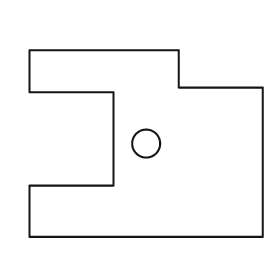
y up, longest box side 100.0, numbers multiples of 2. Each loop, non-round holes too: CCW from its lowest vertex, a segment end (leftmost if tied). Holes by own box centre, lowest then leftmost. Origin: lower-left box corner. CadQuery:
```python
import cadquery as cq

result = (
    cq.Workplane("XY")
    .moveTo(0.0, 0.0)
    .lineTo(100.0, 0.0)
    .lineTo(100.0, 64.0)
    .lineTo(64.0, 64.0)
    .lineTo(64.0, 80.0)
    .lineTo(0.0, 80.0)
    .lineTo(0.0, 62.0)
    .lineTo(36.0, 62.0)
    .lineTo(36.0, 22.0)
    .lineTo(0.0, 22.0)
    .close()
    .moveTo(50.0, 40.0)
    .circle(6.0)
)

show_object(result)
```